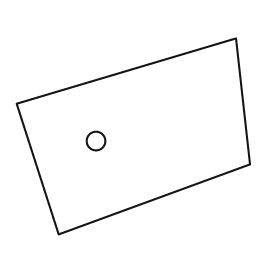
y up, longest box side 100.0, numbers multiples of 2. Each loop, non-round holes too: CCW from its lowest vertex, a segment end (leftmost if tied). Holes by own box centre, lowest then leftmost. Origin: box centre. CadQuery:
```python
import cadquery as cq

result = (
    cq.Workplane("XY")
    .moveTo(-32.0, -42.0)
    .lineTo(50.0, -12.0)
    .lineTo(44.0, 42.0)
    .lineTo(-50.0, 14.0)
    .close()
    .moveTo(-16.0, -2.0)
    .circle(4.0)
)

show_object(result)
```